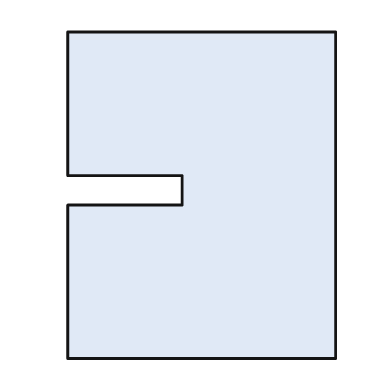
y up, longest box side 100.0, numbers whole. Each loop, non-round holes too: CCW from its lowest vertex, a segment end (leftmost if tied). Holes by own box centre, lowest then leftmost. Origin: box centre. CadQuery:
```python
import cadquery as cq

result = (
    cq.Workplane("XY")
    .moveTo(-41.0, -50.0)
    .lineTo(41.0, -50.0)
    .lineTo(41.0, 50.0)
    .lineTo(-41.0, 50.0)
    .lineTo(-41.0, 6.0)
    .lineTo(-6.0, 6.0)
    .lineTo(-6.0, -3.0)
    .lineTo(-41.0, -3.0)
    .close()
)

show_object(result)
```